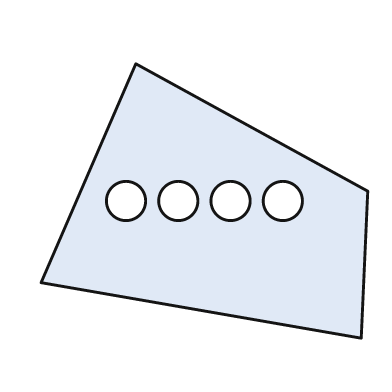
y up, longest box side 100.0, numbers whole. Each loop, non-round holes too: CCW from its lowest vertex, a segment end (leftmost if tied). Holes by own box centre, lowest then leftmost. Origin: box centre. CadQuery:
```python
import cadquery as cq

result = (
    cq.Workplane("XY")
    .moveTo(48.0, -42.0)
    .lineTo(50.0, 3.0)
    .lineTo(-21.0, 42.0)
    .lineTo(-50.0, -25.0)
    .close()
    .moveTo(-24.0, 0.0)
    .circle(6.0)
    .moveTo(-8.0, 0.0)
    .circle(6.0)
    .moveTo(8.0, 0.0)
    .circle(6.0)
    .moveTo(24.0, 0.0)
    .circle(6.0)
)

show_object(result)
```